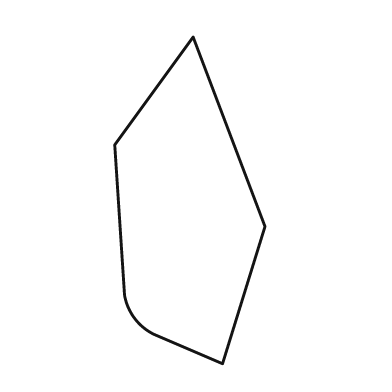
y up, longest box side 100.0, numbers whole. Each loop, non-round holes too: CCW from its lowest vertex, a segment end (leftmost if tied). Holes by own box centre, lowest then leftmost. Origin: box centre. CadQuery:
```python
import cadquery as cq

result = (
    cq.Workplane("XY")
    .moveTo(10.0, -50.0)
    .lineTo(23.0, -8.0)
    .lineTo(1.0, 50.0)
    .lineTo(-23.0, 17.0)
    .lineTo(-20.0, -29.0)
    .threePointArc((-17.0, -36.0), (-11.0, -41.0))
    .close()
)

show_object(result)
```